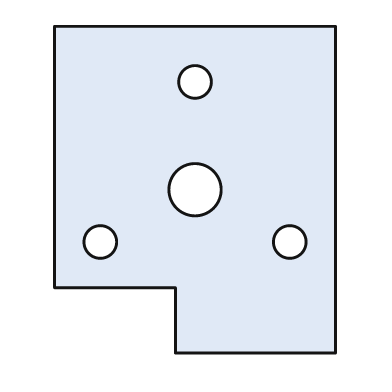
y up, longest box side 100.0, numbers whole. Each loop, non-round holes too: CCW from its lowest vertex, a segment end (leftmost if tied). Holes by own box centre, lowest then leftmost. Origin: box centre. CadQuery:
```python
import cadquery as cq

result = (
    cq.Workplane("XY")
    .moveTo(-6.0, -50.0)
    .lineTo(43.0, -50.0)
    .lineTo(43.0, 50.0)
    .lineTo(-43.0, 50.0)
    .lineTo(-43.0, -30.0)
    .lineTo(-6.0, -30.0)
    .close()
    .moveTo(-29.0, -16.0)
    .circle(5.0)
    .moveTo(29.0, -16.0)
    .circle(5.0)
    .moveTo(0.0, 0.0)
    .circle(8.0)
    .moveTo(0.0, 33.0)
    .circle(5.0)
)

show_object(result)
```